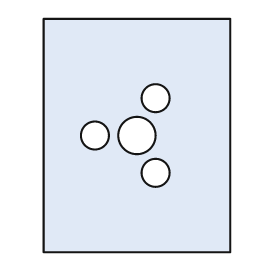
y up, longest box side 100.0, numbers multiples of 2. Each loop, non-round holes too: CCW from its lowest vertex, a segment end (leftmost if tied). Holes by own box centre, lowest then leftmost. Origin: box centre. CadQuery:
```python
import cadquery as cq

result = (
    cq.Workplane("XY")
    .moveTo(-40.0, -50.0)
    .lineTo(40.0, -50.0)
    .lineTo(40.0, 50.0)
    .lineTo(-40.0, 50.0)
    .close()
    .moveTo(8.0, -16.0)
    .circle(6.0)
    .moveTo(-18.0, 0.0)
    .circle(6.0)
    .moveTo(0.0, 0.0)
    .circle(8.0)
    .moveTo(8.0, 16.0)
    .circle(6.0)
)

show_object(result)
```